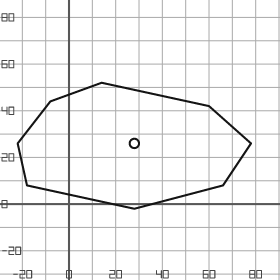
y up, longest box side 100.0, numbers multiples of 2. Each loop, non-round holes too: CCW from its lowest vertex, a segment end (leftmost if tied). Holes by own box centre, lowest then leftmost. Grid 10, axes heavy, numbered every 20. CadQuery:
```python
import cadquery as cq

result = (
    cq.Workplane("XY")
    .moveTo(28.0, -2.0)
    .lineTo(66.0, 8.0)
    .lineTo(78.0, 26.0)
    .lineTo(60.0, 42.0)
    .lineTo(14.0, 52.0)
    .lineTo(-8.0, 44.0)
    .lineTo(-22.0, 26.0)
    .lineTo(-18.0, 8.0)
    .close()
    .moveTo(28.0, 26.0)
    .circle(2.0)
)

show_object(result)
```